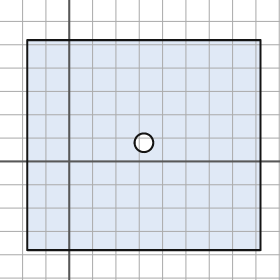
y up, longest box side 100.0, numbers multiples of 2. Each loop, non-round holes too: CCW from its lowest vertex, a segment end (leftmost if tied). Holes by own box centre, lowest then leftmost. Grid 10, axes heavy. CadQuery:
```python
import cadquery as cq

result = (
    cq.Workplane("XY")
    .moveTo(-18.0, -38.0)
    .lineTo(82.0, -38.0)
    .lineTo(82.0, 52.0)
    .lineTo(-18.0, 52.0)
    .close()
    .moveTo(32.0, 8.0)
    .circle(4.0)
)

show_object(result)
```